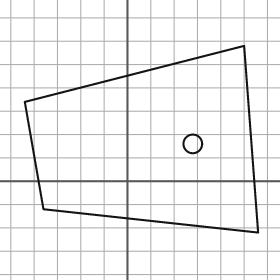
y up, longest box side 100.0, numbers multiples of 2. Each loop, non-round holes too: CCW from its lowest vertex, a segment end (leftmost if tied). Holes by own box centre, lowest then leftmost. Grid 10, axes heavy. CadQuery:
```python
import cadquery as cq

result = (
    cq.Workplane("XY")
    .moveTo(56.0, -22.0)
    .lineTo(50.0, 58.0)
    .lineTo(-44.0, 34.0)
    .lineTo(-36.0, -12.0)
    .close()
    .moveTo(28.0, 16.0)
    .circle(4.0)
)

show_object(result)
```